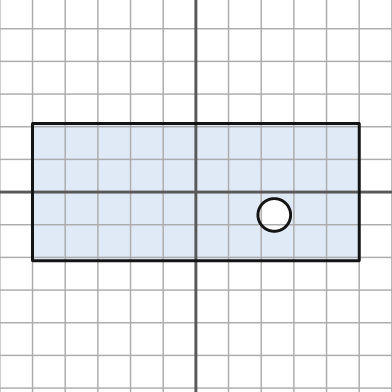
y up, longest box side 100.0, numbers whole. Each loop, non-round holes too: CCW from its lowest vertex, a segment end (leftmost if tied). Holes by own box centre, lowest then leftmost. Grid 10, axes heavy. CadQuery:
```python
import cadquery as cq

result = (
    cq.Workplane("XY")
    .moveTo(-50.0, -21.0)
    .lineTo(50.0, -21.0)
    .lineTo(50.0, 21.0)
    .lineTo(-50.0, 21.0)
    .close()
    .moveTo(24.0, -7.0)
    .circle(5.0)
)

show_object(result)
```